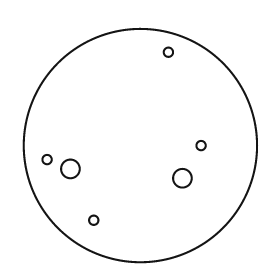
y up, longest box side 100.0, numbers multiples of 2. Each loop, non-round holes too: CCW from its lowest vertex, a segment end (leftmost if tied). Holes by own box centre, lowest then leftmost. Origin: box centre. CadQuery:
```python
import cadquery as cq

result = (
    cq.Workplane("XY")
    .moveTo(0.0, 0.0)
    .circle(50.0)
    .moveTo(-20.0, -32.0)
    .circle(2.0)
    .moveTo(18.0, -14.0)
    .circle(4.0)
    .moveTo(-30.0, -10.0)
    .circle(4.0)
    .moveTo(-40.0, -6.0)
    .circle(2.0)
    .moveTo(26.0, 0.0)
    .circle(2.0)
    .moveTo(12.0, 40.0)
    .circle(2.0)
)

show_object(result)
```